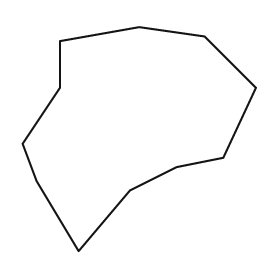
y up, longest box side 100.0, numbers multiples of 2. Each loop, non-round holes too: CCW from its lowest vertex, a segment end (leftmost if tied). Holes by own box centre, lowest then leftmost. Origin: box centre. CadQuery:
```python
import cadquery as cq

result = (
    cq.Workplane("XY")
    .moveTo(-26.0, -48.0)
    .lineTo(-4.0, -22.0)
    .lineTo(16.0, -12.0)
    .lineTo(36.0, -8.0)
    .lineTo(50.0, 22.0)
    .lineTo(28.0, 44.0)
    .lineTo(0.0, 48.0)
    .lineTo(-34.0, 42.0)
    .lineTo(-34.0, 22.0)
    .lineTo(-50.0, -2.0)
    .lineTo(-44.0, -18.0)
    .close()
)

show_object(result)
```